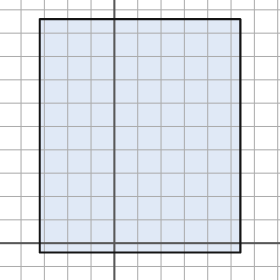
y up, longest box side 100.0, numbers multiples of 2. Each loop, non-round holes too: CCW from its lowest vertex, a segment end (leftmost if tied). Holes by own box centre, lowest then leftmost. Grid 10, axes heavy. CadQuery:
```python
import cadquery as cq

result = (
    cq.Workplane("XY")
    .moveTo(-32.0, -4.0)
    .lineTo(54.0, -4.0)
    .lineTo(54.0, 96.0)
    .lineTo(-32.0, 96.0)
    .close()
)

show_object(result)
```